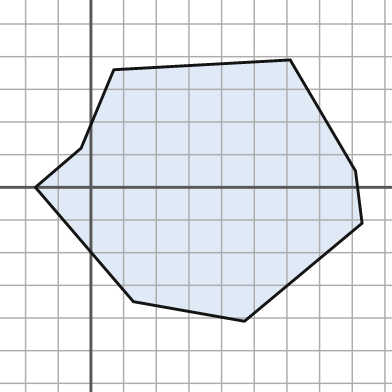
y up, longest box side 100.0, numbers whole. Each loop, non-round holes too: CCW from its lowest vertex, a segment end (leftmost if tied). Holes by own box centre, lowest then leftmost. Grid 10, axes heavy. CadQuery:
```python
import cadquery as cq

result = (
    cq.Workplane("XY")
    .moveTo(47.0, -41.0)
    .lineTo(83.0, -11.0)
    .lineTo(81.0, 5.0)
    .lineTo(61.0, 39.0)
    .lineTo(7.0, 36.0)
    .lineTo(-3.0, 12.0)
    .lineTo(-17.0, 0.0)
    .lineTo(13.0, -35.0)
    .close()
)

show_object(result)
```